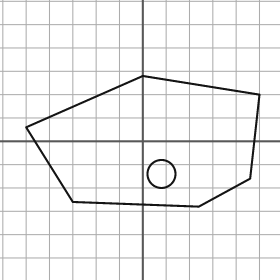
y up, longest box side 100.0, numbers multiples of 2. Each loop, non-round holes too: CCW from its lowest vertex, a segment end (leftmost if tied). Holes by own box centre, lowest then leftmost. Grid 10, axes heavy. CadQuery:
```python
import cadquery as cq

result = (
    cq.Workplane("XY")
    .moveTo(24.0, -28.0)
    .lineTo(46.0, -16.0)
    .lineTo(50.0, 20.0)
    .lineTo(0.0, 28.0)
    .lineTo(-50.0, 6.0)
    .lineTo(-30.0, -26.0)
    .close()
    .moveTo(8.0, -14.0)
    .circle(6.0)
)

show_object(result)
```